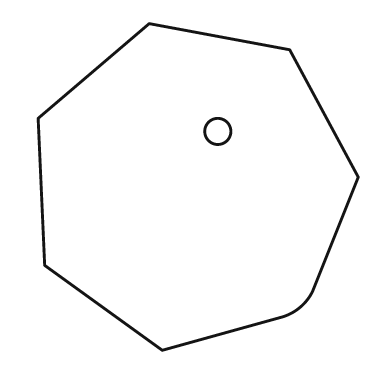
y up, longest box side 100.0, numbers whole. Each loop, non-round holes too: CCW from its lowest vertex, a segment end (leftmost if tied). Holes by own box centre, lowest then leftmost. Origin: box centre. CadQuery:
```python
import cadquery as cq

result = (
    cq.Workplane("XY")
    .moveTo(-11.0, -50.0)
    .lineTo(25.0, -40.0)
    .threePointArc((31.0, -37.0), (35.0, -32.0))
    .lineTo(49.0, 3.0)
    .lineTo(28.0, 42.0)
    .lineTo(-15.0, 50.0)
    .lineTo(-49.0, 21.0)
    .lineTo(-47.0, -24.0)
    .close()
    .moveTo(6.0, 17.0)
    .circle(4.0)
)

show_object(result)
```